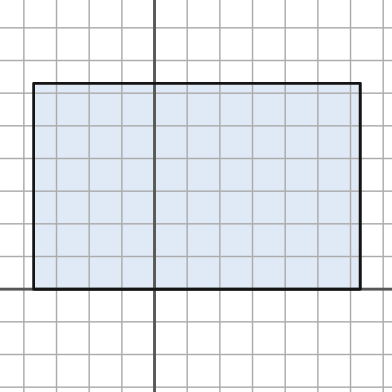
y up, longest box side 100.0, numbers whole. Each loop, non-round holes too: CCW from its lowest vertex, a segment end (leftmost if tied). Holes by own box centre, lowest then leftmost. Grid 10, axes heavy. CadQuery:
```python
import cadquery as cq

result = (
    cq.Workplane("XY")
    .moveTo(-37.0, 0.0)
    .lineTo(63.0, 0.0)
    .lineTo(63.0, 63.0)
    .lineTo(-37.0, 63.0)
    .close()
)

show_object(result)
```